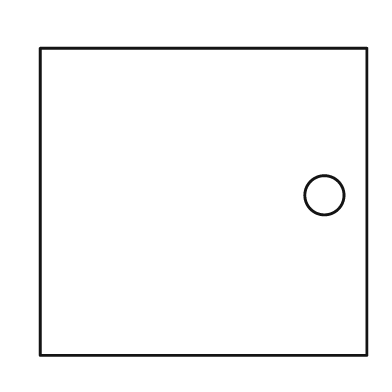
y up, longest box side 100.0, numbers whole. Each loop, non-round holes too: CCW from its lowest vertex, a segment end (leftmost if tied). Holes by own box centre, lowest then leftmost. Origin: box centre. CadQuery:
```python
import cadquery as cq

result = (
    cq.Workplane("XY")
    .moveTo(-50.0, -47.0)
    .lineTo(50.0, -47.0)
    .lineTo(50.0, 47.0)
    .lineTo(-50.0, 47.0)
    .close()
    .moveTo(37.0, 2.0)
    .circle(6.0)
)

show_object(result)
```